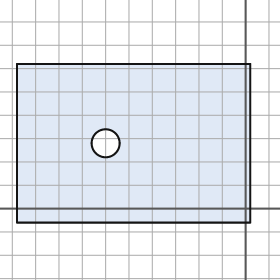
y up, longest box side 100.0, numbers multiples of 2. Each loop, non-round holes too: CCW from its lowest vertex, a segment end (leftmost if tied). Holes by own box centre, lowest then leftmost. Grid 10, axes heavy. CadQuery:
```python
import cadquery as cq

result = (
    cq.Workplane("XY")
    .moveTo(-98.0, -6.0)
    .lineTo(2.0, -6.0)
    .lineTo(2.0, 62.0)
    .lineTo(-98.0, 62.0)
    .close()
    .moveTo(-60.0, 28.0)
    .circle(6.0)
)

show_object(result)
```